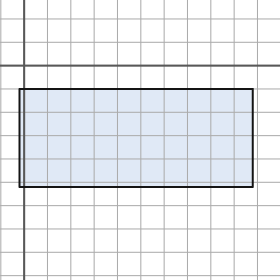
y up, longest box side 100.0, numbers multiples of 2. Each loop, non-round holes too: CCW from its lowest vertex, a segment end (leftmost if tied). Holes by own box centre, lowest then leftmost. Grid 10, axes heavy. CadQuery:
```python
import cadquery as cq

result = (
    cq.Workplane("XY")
    .moveTo(-2.0, -52.0)
    .lineTo(98.0, -52.0)
    .lineTo(98.0, -10.0)
    .lineTo(-2.0, -10.0)
    .close()
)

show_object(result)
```